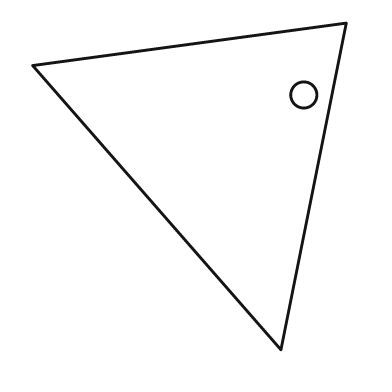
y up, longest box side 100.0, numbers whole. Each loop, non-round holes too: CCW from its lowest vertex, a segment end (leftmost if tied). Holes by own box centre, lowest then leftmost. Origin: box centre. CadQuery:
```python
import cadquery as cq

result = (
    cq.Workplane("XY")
    .moveTo(28.0, -50.0)
    .lineTo(48.0, 50.0)
    .lineTo(-48.0, 37.0)
    .close()
    .moveTo(35.0, 28.0)
    .circle(4.0)
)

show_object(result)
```